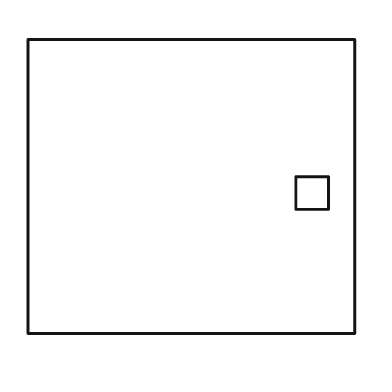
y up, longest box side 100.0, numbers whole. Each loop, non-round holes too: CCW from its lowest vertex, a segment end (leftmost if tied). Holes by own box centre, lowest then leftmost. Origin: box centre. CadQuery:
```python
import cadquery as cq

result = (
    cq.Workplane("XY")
    .moveTo(-50.0, -45.0)
    .lineTo(50.0, -45.0)
    .lineTo(50.0, 45.0)
    .lineTo(-50.0, 45.0)
    .close()
    .moveTo(32.0, -7.0)
    .lineTo(42.0, -7.0)
    .lineTo(42.0, 3.0)
    .lineTo(32.0, 3.0)
    .close()
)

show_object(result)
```